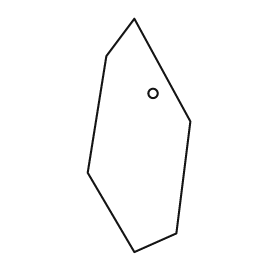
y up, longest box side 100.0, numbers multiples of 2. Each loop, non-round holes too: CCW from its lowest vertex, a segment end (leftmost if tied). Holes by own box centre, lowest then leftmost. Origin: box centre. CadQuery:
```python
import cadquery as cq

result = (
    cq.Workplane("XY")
    .moveTo(-2.0, -50.0)
    .lineTo(16.0, -42.0)
    .lineTo(22.0, 6.0)
    .lineTo(-2.0, 50.0)
    .lineTo(-14.0, 34.0)
    .lineTo(-22.0, -16.0)
    .close()
    .moveTo(6.0, 18.0)
    .circle(2.0)
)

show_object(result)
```